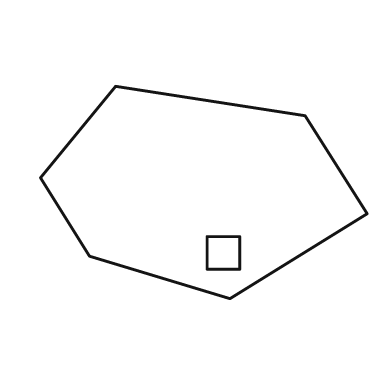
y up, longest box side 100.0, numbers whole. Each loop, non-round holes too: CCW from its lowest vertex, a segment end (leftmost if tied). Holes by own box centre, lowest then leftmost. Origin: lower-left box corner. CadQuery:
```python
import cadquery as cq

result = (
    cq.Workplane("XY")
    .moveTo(58.0, 0.0)
    .lineTo(100.0, 26.0)
    .lineTo(81.0, 56.0)
    .lineTo(23.0, 65.0)
    .lineTo(0.0, 37.0)
    .lineTo(15.0, 13.0)
    .close()
    .moveTo(51.0, 9.0)
    .lineTo(61.0, 9.0)
    .lineTo(61.0, 19.0)
    .lineTo(51.0, 19.0)
    .close()
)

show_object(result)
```